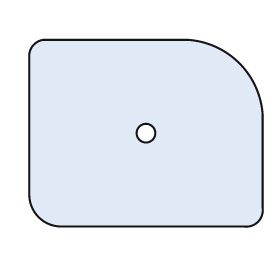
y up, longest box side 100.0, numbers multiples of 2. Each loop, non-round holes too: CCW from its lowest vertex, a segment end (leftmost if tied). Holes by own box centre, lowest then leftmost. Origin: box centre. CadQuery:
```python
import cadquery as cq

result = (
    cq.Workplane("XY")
    .moveTo(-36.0, -40.0)
    .lineTo(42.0, -40.0)
    .threePointArc((48.0, -38.0), (50.0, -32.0))
    .lineTo(50.0, 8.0)
    .threePointArc((40.0, 30.0), (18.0, 40.0))
    .lineTo(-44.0, 40.0)
    .threePointArc((-48.0, 38.0), (-50.0, 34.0))
    .lineTo(-50.0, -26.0)
    .threePointArc((-46.0, -36.0), (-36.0, -40.0))
    .close()
    .moveTo(0.0, 0.0)
    .circle(4.0)
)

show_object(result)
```